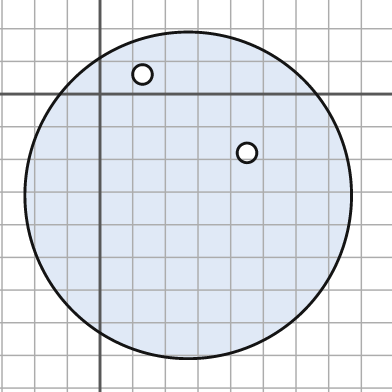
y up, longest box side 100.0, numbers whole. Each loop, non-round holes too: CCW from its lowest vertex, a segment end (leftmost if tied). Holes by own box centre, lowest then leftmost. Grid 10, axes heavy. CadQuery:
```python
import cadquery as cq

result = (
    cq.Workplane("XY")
    .moveTo(27.0, -31.0)
    .circle(50.0)
    .moveTo(45.0, -18.0)
    .circle(3.0)
    .moveTo(13.0, 6.0)
    .circle(3.0)
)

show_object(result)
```